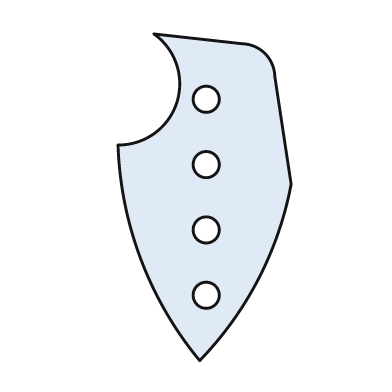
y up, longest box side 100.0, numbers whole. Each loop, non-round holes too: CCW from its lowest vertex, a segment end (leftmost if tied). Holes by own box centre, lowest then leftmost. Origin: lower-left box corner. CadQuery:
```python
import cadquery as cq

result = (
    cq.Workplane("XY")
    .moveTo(25.0, 0.0)
    .threePointArc((43.0, 25.0), (53.0, 54.0))
    .lineTo(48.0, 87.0)
    .threePointArc((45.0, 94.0), (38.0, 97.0))
    .lineTo(11.0, 100.0)
    .threePointArc((18.0, 79.0), (0.0, 66.0))
    .threePointArc((7.0, 31.0), (25.0, 0.0))
    .close()
    .moveTo(27.0, 20.0)
    .circle(4.0)
    .moveTo(27.0, 40.0)
    .circle(4.0)
    .moveTo(27.0, 60.0)
    .circle(4.0)
    .moveTo(27.0, 80.0)
    .circle(4.0)
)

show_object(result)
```